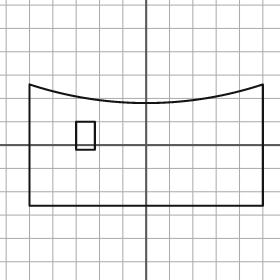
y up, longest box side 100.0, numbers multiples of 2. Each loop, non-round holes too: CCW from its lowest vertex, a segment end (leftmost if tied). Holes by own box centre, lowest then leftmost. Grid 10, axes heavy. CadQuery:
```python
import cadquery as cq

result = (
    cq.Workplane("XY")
    .moveTo(-50.0, -26.0)
    .lineTo(50.0, -26.0)
    .lineTo(50.0, 26.0)
    .threePointArc((0.0, 18.0), (-50.0, 26.0))
    .close()
    .moveTo(-30.0, -2.0)
    .lineTo(-22.0, -2.0)
    .lineTo(-22.0, 10.0)
    .lineTo(-30.0, 10.0)
    .close()
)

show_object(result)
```